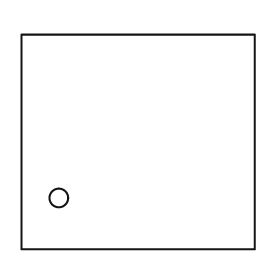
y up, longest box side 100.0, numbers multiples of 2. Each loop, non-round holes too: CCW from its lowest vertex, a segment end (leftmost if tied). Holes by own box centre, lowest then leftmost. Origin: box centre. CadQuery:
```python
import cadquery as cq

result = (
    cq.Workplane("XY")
    .moveTo(-50.0, -46.0)
    .lineTo(50.0, -46.0)
    .lineTo(50.0, 46.0)
    .lineTo(-50.0, 46.0)
    .close()
    .moveTo(-34.0, -24.0)
    .circle(4.0)
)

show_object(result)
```